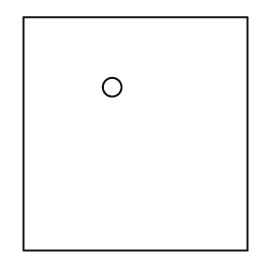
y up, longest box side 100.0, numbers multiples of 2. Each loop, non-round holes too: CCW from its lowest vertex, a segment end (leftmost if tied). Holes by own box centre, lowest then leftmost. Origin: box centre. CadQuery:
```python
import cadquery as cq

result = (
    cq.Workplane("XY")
    .moveTo(-48.0, -50.0)
    .lineTo(48.0, -50.0)
    .lineTo(48.0, 50.0)
    .lineTo(-48.0, 50.0)
    .close()
    .moveTo(-10.0, 20.0)
    .circle(4.0)
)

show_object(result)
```